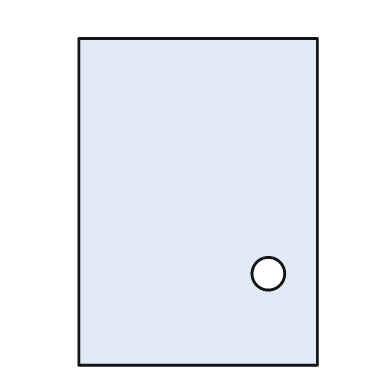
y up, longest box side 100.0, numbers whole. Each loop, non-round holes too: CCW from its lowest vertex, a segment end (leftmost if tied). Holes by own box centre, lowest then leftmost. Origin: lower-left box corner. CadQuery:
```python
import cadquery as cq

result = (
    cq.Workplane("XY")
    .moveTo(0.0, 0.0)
    .lineTo(73.0, 0.0)
    .lineTo(73.0, 100.0)
    .lineTo(0.0, 100.0)
    .close()
    .moveTo(58.0, 28.0)
    .circle(5.0)
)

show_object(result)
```